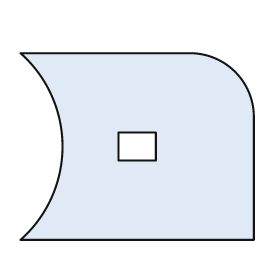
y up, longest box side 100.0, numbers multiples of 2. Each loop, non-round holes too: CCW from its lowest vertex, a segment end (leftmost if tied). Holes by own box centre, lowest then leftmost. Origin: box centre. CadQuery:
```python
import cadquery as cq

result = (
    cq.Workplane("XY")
    .moveTo(-50.0, -40.0)
    .lineTo(50.0, -40.0)
    .lineTo(50.0, 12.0)
    .threePointArc((42.0, 32.0), (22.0, 40.0))
    .lineTo(-50.0, 40.0)
    .threePointArc((-32.0, 0.0), (-50.0, -40.0))
    .close()
    .moveTo(-8.0, -6.0)
    .lineTo(8.0, -6.0)
    .lineTo(8.0, 6.0)
    .lineTo(-8.0, 6.0)
    .close()
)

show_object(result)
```